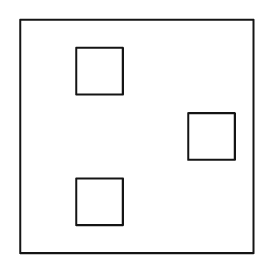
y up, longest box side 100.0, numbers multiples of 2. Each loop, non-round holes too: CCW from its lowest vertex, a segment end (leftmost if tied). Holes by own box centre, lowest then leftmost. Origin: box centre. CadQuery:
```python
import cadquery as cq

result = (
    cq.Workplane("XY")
    .moveTo(-50.0, -50.0)
    .lineTo(50.0, -50.0)
    .lineTo(50.0, 50.0)
    .lineTo(-50.0, 50.0)
    .close()
    .moveTo(-26.0, -38.0)
    .lineTo(-6.0, -38.0)
    .lineTo(-6.0, -18.0)
    .lineTo(-26.0, -18.0)
    .close()
    .moveTo(22.0, -10.0)
    .lineTo(42.0, -10.0)
    .lineTo(42.0, 10.0)
    .lineTo(22.0, 10.0)
    .close()
    .moveTo(-26.0, 18.0)
    .lineTo(-6.0, 18.0)
    .lineTo(-6.0, 38.0)
    .lineTo(-26.0, 38.0)
    .close()
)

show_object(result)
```